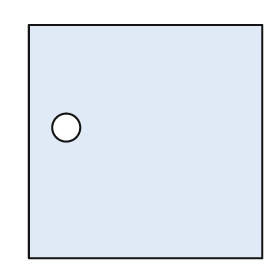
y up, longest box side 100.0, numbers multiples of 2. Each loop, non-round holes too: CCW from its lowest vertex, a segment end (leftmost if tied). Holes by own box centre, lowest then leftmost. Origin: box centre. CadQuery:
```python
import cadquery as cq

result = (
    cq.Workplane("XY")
    .moveTo(-50.0, -50.0)
    .lineTo(50.0, -50.0)
    .lineTo(50.0, 50.0)
    .lineTo(-50.0, 50.0)
    .close()
    .moveTo(-34.0, 6.0)
    .circle(6.0)
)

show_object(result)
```